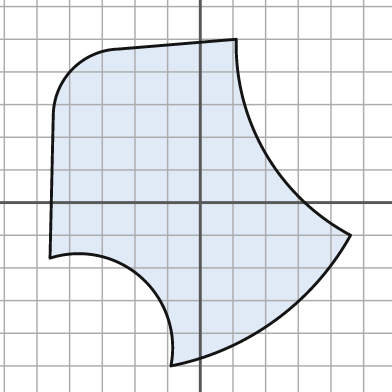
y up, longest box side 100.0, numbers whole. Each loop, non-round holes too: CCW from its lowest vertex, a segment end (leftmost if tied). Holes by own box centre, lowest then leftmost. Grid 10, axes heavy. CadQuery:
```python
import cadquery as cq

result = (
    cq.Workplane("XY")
    .moveTo(-9.0, -50.0)
    .threePointArc((23.0, -36.0), (46.0, -10.0))
    .threePointArc((20.0, 15.0), (11.0, 50.0))
    .lineTo(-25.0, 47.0)
    .threePointArc((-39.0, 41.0), (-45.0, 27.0))
    .lineTo(-46.0, -17.0)
    .threePointArc((-18.0, -23.0), (-9.0, -50.0))
    .close()
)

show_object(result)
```